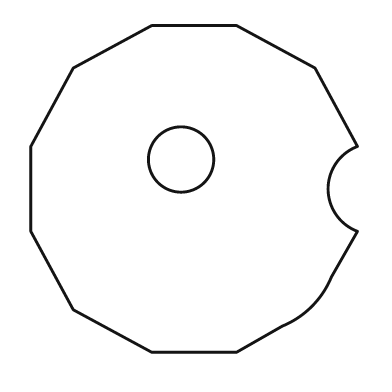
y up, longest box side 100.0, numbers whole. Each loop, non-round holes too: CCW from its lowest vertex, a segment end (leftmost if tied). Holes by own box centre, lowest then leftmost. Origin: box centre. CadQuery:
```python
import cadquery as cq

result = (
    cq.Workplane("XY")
    .moveTo(-13.0, -50.0)
    .lineTo(13.0, -50.0)
    .lineTo(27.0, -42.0)
    .threePointArc((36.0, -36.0), (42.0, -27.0))
    .lineTo(50.0, -13.0)
    .threePointArc((41.0, 0.0), (50.0, 13.0))
    .lineTo(37.0, 37.0)
    .lineTo(13.0, 50.0)
    .lineTo(-13.0, 50.0)
    .lineTo(-37.0, 37.0)
    .lineTo(-50.0, 13.0)
    .lineTo(-50.0, -13.0)
    .lineTo(-37.0, -37.0)
    .close()
    .moveTo(-4.0, 9.0)
    .circle(10.0)
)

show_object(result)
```